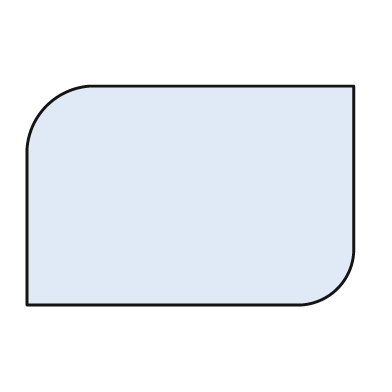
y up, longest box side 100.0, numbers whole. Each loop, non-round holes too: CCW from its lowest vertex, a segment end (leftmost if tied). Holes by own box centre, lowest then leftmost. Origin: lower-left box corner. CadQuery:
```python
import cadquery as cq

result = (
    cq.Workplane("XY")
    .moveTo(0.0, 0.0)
    .lineTo(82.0, 0.0)
    .threePointArc((95.0, 5.0), (100.0, 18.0))
    .lineTo(100.0, 67.0)
    .lineTo(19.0, 67.0)
    .threePointArc((6.0, 61.0), (0.0, 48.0))
    .close()
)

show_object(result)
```